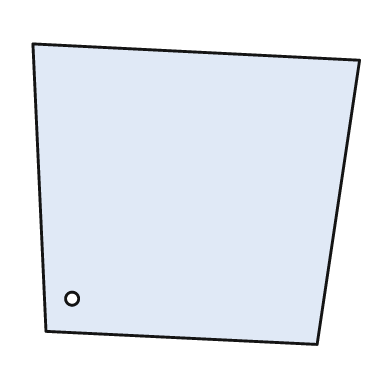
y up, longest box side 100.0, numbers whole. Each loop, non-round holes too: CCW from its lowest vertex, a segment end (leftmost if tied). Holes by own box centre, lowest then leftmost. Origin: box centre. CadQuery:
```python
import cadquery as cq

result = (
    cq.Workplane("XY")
    .moveTo(37.0, -46.0)
    .lineTo(50.0, 41.0)
    .lineTo(-50.0, 46.0)
    .lineTo(-46.0, -42.0)
    .close()
    .moveTo(-38.0, -32.0)
    .circle(2.0)
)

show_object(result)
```